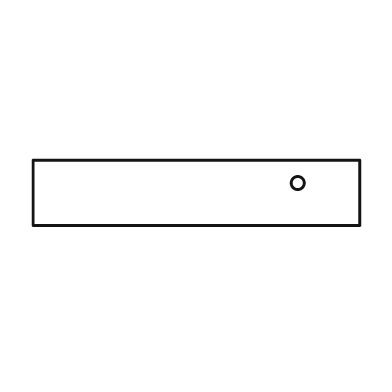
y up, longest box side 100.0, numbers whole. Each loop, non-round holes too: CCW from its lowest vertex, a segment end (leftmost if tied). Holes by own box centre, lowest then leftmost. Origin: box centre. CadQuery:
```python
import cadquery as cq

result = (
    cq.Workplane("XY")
    .moveTo(-50.0, -10.0)
    .lineTo(50.0, -10.0)
    .lineTo(50.0, 10.0)
    .lineTo(-50.0, 10.0)
    .close()
    .moveTo(31.0, 3.0)
    .circle(2.0)
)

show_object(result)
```